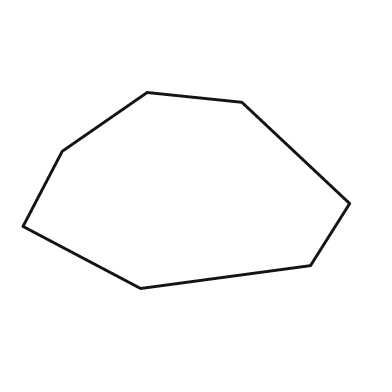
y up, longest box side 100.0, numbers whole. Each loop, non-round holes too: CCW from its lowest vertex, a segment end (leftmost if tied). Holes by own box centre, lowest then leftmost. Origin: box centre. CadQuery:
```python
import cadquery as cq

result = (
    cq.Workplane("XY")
    .moveTo(-14.0, -30.0)
    .lineTo(38.0, -23.0)
    .lineTo(50.0, -4.0)
    .lineTo(17.0, 27.0)
    .lineTo(-12.0, 30.0)
    .lineTo(-38.0, 12.0)
    .lineTo(-50.0, -11.0)
    .close()
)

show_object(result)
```